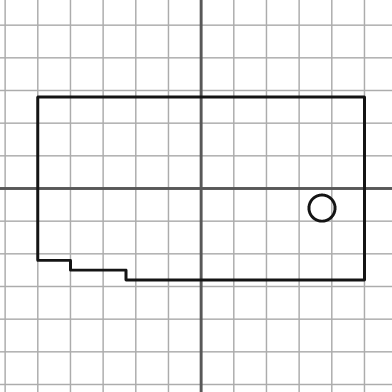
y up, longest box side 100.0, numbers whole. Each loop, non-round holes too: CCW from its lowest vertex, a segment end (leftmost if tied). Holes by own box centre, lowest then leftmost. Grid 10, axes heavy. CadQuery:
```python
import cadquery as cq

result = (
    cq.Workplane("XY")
    .moveTo(-23.0, -28.0)
    .lineTo(50.0, -28.0)
    .lineTo(50.0, 28.0)
    .lineTo(-50.0, 28.0)
    .lineTo(-50.0, -22.0)
    .lineTo(-40.0, -22.0)
    .lineTo(-40.0, -25.0)
    .lineTo(-23.0, -25.0)
    .close()
    .moveTo(37.0, -6.0)
    .circle(4.0)
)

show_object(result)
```